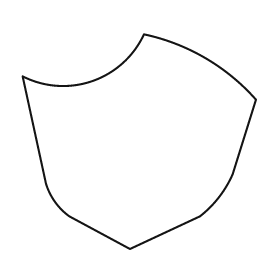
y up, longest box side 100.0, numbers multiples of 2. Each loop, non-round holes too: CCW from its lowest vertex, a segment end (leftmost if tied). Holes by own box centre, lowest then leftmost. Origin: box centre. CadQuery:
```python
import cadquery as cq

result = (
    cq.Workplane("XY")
    .moveTo(-4.0, -46.0)
    .lineTo(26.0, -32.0)
    .threePointArc((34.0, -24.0), (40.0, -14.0))
    .lineTo(50.0, 18.0)
    .threePointArc((28.0, 36.0), (2.0, 46.0))
    .threePointArc((-20.0, 26.0), (-50.0, 28.0))
    .lineTo(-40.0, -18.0)
    .threePointArc((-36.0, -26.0), (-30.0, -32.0))
    .close()
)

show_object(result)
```